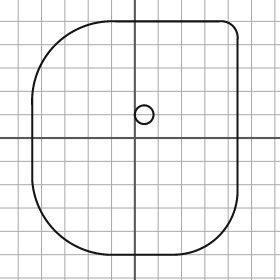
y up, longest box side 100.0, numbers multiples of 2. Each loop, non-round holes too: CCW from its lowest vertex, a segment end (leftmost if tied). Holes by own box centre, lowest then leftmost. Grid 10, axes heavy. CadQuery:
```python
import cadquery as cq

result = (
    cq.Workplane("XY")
    .moveTo(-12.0, -50.0)
    .lineTo(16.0, -50.0)
    .threePointArc((36.0, -42.0), (44.0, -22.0))
    .lineTo(44.0, 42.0)
    .threePointArc((42.0, 48.0), (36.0, 50.0))
    .lineTo(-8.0, 50.0)
    .threePointArc((-34.0, 40.0), (-44.0, 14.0))
    .lineTo(-44.0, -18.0)
    .threePointArc((-34.0, -40.0), (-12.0, -50.0))
    .close()
    .moveTo(4.0, 10.0)
    .circle(4.0)
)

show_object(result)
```